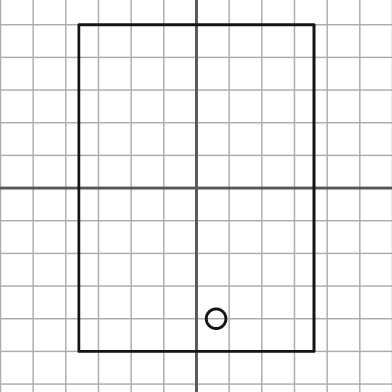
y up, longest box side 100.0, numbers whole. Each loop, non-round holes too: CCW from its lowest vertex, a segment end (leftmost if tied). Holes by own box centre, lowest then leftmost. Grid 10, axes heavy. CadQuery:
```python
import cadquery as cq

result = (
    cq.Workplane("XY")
    .moveTo(-36.0, -50.0)
    .lineTo(36.0, -50.0)
    .lineTo(36.0, 50.0)
    .lineTo(-36.0, 50.0)
    .close()
    .moveTo(6.0, -40.0)
    .circle(3.0)
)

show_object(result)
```